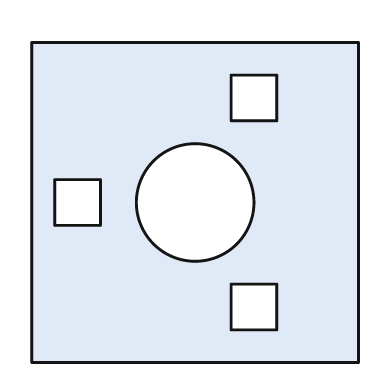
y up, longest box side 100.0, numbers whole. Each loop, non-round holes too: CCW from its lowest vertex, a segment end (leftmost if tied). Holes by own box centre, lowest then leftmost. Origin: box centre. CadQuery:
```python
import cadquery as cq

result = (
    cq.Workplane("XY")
    .moveTo(-50.0, -49.0)
    .lineTo(50.0, -49.0)
    .lineTo(50.0, 49.0)
    .lineTo(-50.0, 49.0)
    .close()
    .moveTo(11.0, -39.0)
    .lineTo(25.0, -39.0)
    .lineTo(25.0, -25.0)
    .lineTo(11.0, -25.0)
    .close()
    .moveTo(-43.0, -7.0)
    .lineTo(-29.0, -7.0)
    .lineTo(-29.0, 7.0)
    .lineTo(-43.0, 7.0)
    .close()
    .moveTo(0.0, 0.0)
    .circle(18.0)
    .moveTo(11.0, 25.0)
    .lineTo(25.0, 25.0)
    .lineTo(25.0, 39.0)
    .lineTo(11.0, 39.0)
    .close()
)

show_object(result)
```